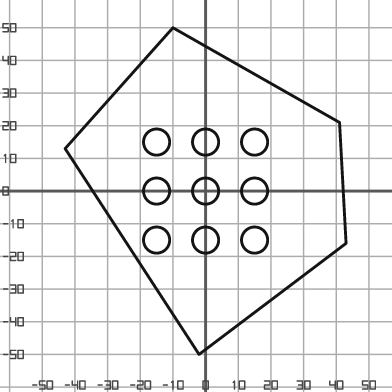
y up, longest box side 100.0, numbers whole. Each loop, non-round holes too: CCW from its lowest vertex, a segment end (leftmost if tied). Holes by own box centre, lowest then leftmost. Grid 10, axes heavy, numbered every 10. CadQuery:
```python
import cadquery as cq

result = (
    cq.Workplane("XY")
    .moveTo(-2.0, -50.0)
    .lineTo(43.0, -16.0)
    .lineTo(41.0, 21.0)
    .lineTo(-10.0, 50.0)
    .lineTo(-43.0, 13.0)
    .close()
    .moveTo(-15.0, -15.0)
    .circle(4.0)
    .moveTo(0.0, -15.0)
    .circle(4.0)
    .moveTo(15.0, -15.0)
    .circle(4.0)
    .moveTo(-15.0, 0.0)
    .circle(4.0)
    .moveTo(0.0, 0.0)
    .circle(4.0)
    .moveTo(15.0, 0.0)
    .circle(4.0)
    .moveTo(-15.0, 15.0)
    .circle(4.0)
    .moveTo(0.0, 15.0)
    .circle(4.0)
    .moveTo(15.0, 15.0)
    .circle(4.0)
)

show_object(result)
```